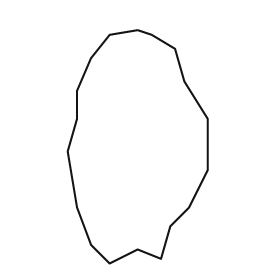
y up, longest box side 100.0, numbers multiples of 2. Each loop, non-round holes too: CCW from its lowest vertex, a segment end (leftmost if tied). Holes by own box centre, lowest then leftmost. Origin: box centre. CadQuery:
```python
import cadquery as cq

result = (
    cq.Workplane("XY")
    .moveTo(-12.0, -50.0)
    .lineTo(0.0, -44.0)
    .lineTo(10.0, -48.0)
    .lineTo(14.0, -34.0)
    .lineTo(22.0, -26.0)
    .lineTo(30.0, -10.0)
    .lineTo(30.0, 12.0)
    .lineTo(20.0, 28.0)
    .lineTo(16.0, 42.0)
    .lineTo(6.0, 48.0)
    .lineTo(0.0, 50.0)
    .lineTo(-12.0, 48.0)
    .lineTo(-20.0, 38.0)
    .lineTo(-26.0, 24.0)
    .lineTo(-26.0, 12.0)
    .lineTo(-30.0, -2.0)
    .lineTo(-26.0, -26.0)
    .lineTo(-20.0, -42.0)
    .close()
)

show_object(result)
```